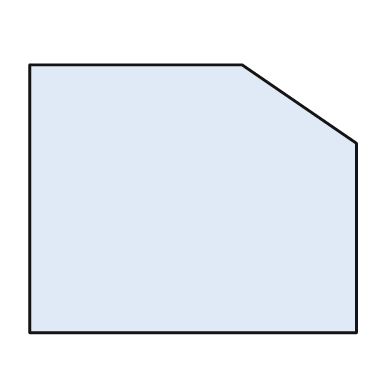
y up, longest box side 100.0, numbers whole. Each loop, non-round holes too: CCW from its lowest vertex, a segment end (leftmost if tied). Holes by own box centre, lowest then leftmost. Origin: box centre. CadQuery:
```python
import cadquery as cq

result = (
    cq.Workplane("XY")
    .moveTo(-50.0, -41.0)
    .lineTo(50.0, -41.0)
    .lineTo(50.0, 17.0)
    .lineTo(15.0, 41.0)
    .lineTo(-50.0, 41.0)
    .close()
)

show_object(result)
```